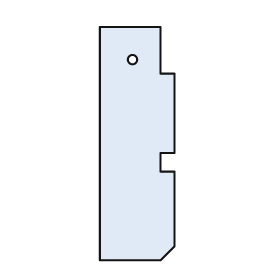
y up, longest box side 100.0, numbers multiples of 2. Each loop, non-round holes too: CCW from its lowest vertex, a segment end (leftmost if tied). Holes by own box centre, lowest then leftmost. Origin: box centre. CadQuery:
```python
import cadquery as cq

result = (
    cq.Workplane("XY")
    .moveTo(-16.0, -50.0)
    .lineTo(10.0, -50.0)
    .lineTo(16.0, -44.0)
    .lineTo(16.0, -12.0)
    .lineTo(10.0, -12.0)
    .lineTo(10.0, -4.0)
    .lineTo(16.0, -4.0)
    .lineTo(16.0, 30.0)
    .lineTo(10.0, 30.0)
    .lineTo(10.0, 50.0)
    .lineTo(-16.0, 50.0)
    .close()
    .moveTo(-2.0, 36.0)
    .circle(2.0)
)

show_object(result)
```